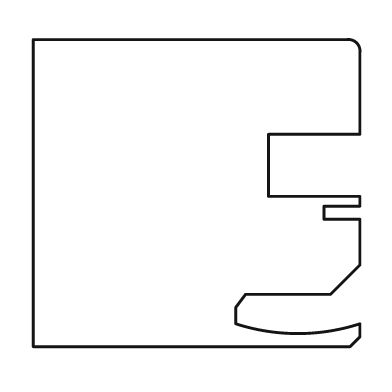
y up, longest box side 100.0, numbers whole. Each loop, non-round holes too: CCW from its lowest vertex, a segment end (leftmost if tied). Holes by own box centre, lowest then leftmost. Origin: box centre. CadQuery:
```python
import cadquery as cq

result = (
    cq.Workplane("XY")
    .moveTo(-50.0, -47.0)
    .lineTo(47.0, -47.0)
    .lineTo(50.0, -44.0)
    .lineTo(50.0, -40.0)
    .threePointArc((31.0, -43.0), (12.0, -40.0))
    .lineTo(12.0, -35.0)
    .lineTo(15.0, -31.0)
    .lineTo(41.0, -31.0)
    .lineTo(50.0, -22.0)
    .lineTo(50.0, -8.0)
    .lineTo(39.0, -8.0)
    .lineTo(39.0, -4.0)
    .lineTo(50.0, -4.0)
    .lineTo(50.0, -1.0)
    .lineTo(22.0, -1.0)
    .lineTo(22.0, 18.0)
    .lineTo(50.0, 18.0)
    .lineTo(50.0, 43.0)
    .threePointArc((49.0, 46.0), (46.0, 47.0))
    .lineTo(-50.0, 47.0)
    .close()
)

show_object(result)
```